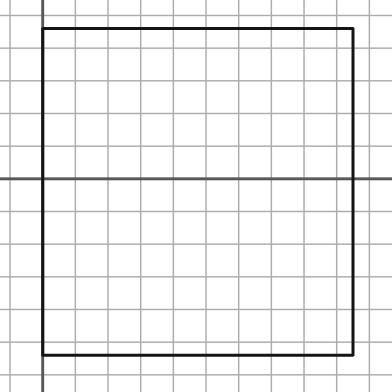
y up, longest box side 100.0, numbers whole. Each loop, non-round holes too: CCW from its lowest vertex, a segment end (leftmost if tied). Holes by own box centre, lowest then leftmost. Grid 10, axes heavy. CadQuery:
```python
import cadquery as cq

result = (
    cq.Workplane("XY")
    .moveTo(0.0, -54.0)
    .lineTo(95.0, -54.0)
    .lineTo(95.0, 46.0)
    .lineTo(0.0, 46.0)
    .close()
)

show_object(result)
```